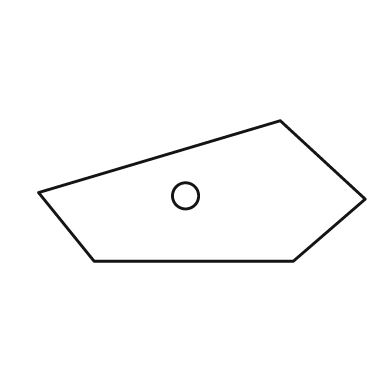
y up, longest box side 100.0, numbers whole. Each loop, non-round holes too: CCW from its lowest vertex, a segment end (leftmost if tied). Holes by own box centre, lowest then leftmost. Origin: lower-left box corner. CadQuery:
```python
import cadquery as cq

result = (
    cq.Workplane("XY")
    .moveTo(17.0, 0.0)
    .lineTo(78.0, 0.0)
    .lineTo(100.0, 19.0)
    .lineTo(74.0, 43.0)
    .lineTo(0.0, 21.0)
    .close()
    .moveTo(45.0, 20.0)
    .circle(4.0)
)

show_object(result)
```